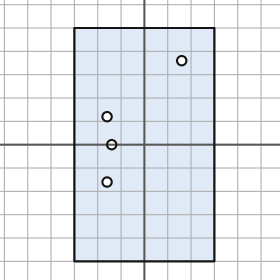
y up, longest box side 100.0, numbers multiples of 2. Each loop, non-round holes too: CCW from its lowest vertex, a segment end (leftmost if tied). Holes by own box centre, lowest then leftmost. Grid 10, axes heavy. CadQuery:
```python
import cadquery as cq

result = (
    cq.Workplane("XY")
    .moveTo(-30.0, -50.0)
    .lineTo(30.0, -50.0)
    .lineTo(30.0, 50.0)
    .lineTo(-30.0, 50.0)
    .close()
    .moveTo(-16.0, -16.0)
    .circle(2.0)
    .moveTo(-14.0, 0.0)
    .circle(2.0)
    .moveTo(-16.0, 12.0)
    .circle(2.0)
    .moveTo(16.0, 36.0)
    .circle(2.0)
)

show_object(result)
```